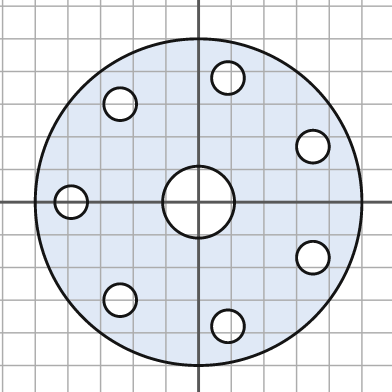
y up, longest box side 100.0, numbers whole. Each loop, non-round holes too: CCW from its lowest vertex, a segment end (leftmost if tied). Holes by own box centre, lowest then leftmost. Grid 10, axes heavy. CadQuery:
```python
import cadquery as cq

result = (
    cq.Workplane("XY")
    .moveTo(0.0, 0.0)
    .circle(50.0)
    .moveTo(9.0, -38.0)
    .circle(5.0)
    .moveTo(-24.0, -30.0)
    .circle(5.0)
    .moveTo(35.0, -17.0)
    .circle(5.0)
    .moveTo(-39.0, 0.0)
    .circle(5.0)
    .moveTo(0.0, 0.0)
    .circle(11.0)
    .moveTo(35.0, 17.0)
    .circle(5.0)
    .moveTo(-24.0, 30.0)
    .circle(5.0)
    .moveTo(9.0, 38.0)
    .circle(5.0)
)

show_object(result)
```